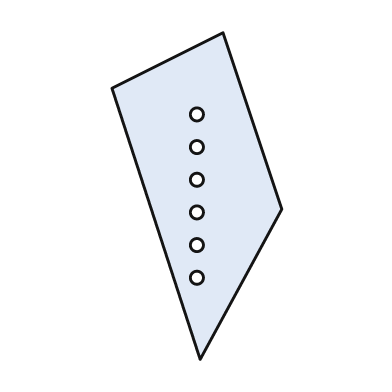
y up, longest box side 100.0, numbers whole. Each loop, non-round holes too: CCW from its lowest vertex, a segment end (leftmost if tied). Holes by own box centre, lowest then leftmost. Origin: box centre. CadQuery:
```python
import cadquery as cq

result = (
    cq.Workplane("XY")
    .moveTo(1.0, -50.0)
    .lineTo(26.0, -4.0)
    .lineTo(8.0, 50.0)
    .lineTo(-26.0, 33.0)
    .close()
    .moveTo(0.0, -25.0)
    .circle(2.0)
    .moveTo(0.0, -15.0)
    .circle(2.0)
    .moveTo(0.0, -5.0)
    .circle(2.0)
    .moveTo(0.0, 5.0)
    .circle(2.0)
    .moveTo(0.0, 15.0)
    .circle(2.0)
    .moveTo(0.0, 25.0)
    .circle(2.0)
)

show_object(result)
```